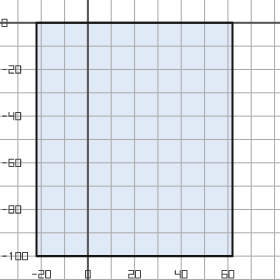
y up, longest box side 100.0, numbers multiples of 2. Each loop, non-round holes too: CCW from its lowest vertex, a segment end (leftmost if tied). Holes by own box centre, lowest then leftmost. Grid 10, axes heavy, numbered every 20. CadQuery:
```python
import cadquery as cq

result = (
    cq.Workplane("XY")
    .moveTo(-22.0, -100.0)
    .lineTo(62.0, -100.0)
    .lineTo(62.0, 0.0)
    .lineTo(-22.0, 0.0)
    .close()
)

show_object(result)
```